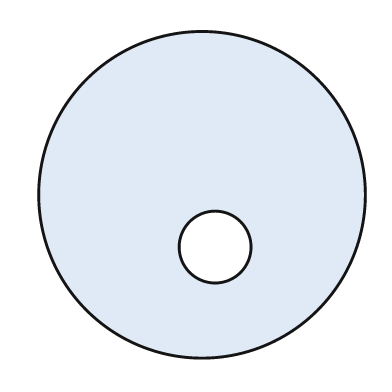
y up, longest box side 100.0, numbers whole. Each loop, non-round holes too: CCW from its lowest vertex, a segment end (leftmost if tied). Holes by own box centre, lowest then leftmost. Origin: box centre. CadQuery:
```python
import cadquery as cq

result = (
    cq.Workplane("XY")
    .moveTo(0.0, 0.0)
    .circle(50.0)
    .moveTo(4.0, -16.0)
    .circle(11.0)
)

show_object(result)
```